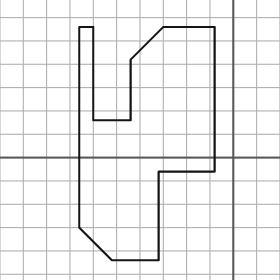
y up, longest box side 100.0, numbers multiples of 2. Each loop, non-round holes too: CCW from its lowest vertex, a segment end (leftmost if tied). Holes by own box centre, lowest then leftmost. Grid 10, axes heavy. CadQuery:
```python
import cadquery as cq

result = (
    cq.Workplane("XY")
    .moveTo(-52.0, -44.0)
    .lineTo(-32.0, -44.0)
    .lineTo(-32.0, -6.0)
    .lineTo(-8.0, -6.0)
    .lineTo(-8.0, 56.0)
    .lineTo(-30.0, 56.0)
    .lineTo(-44.0, 42.0)
    .lineTo(-44.0, 16.0)
    .lineTo(-60.0, 16.0)
    .lineTo(-60.0, 56.0)
    .lineTo(-66.0, 56.0)
    .lineTo(-66.0, -30.0)
    .close()
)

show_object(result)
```